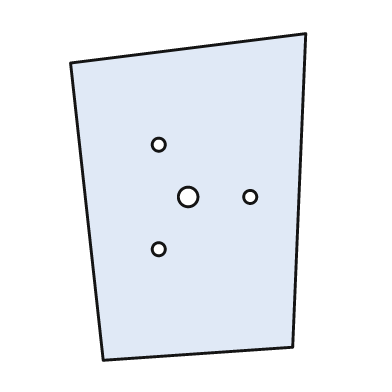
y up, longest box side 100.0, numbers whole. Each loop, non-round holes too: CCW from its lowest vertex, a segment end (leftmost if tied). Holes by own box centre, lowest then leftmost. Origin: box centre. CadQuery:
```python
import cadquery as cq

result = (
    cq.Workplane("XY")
    .moveTo(-26.0, -50.0)
    .lineTo(32.0, -46.0)
    .lineTo(36.0, 50.0)
    .lineTo(-36.0, 41.0)
    .close()
    .moveTo(-9.0, -16.0)
    .circle(2.0)
    .moveTo(0.0, 0.0)
    .circle(3.0)
    .moveTo(19.0, 0.0)
    .circle(2.0)
    .moveTo(-9.0, 16.0)
    .circle(2.0)
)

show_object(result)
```